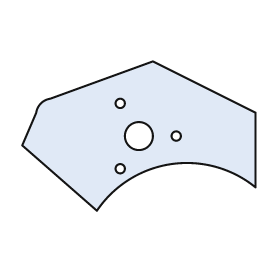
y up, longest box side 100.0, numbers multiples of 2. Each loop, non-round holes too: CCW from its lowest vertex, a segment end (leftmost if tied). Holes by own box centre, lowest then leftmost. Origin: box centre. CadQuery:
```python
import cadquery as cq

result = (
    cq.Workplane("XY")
    .moveTo(-18.0, -32.0)
    .threePointArc((14.0, -12.0), (50.0, -22.0))
    .lineTo(50.0, 10.0)
    .lineTo(6.0, 32.0)
    .lineTo(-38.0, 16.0)
    .threePointArc((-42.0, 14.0), (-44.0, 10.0))
    .lineTo(-50.0, -4.0)
    .close()
    .moveTo(-8.0, -14.0)
    .circle(2.0)
    .moveTo(0.0, 0.0)
    .circle(6.0)
    .moveTo(16.0, 0.0)
    .circle(2.0)
    .moveTo(-8.0, 14.0)
    .circle(2.0)
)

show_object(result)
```